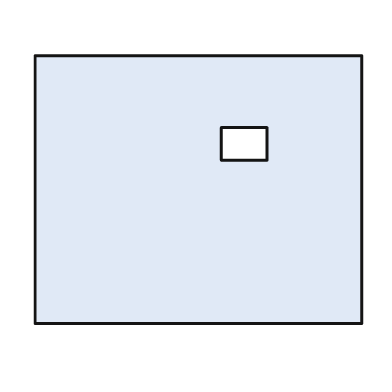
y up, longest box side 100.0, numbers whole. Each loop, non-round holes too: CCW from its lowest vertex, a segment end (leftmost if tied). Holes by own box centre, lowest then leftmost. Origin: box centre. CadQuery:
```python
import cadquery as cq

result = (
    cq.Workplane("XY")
    .moveTo(-50.0, -41.0)
    .lineTo(50.0, -41.0)
    .lineTo(50.0, 41.0)
    .lineTo(-50.0, 41.0)
    .close()
    .moveTo(7.0, 9.0)
    .lineTo(21.0, 9.0)
    .lineTo(21.0, 19.0)
    .lineTo(7.0, 19.0)
    .close()
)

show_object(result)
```